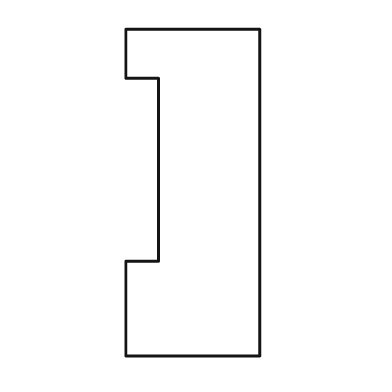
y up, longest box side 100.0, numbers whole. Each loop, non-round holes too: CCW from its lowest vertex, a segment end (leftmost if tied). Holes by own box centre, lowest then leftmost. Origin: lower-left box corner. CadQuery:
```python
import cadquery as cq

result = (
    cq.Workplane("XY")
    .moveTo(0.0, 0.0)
    .lineTo(41.0, 0.0)
    .lineTo(41.0, 100.0)
    .lineTo(0.0, 100.0)
    .lineTo(0.0, 85.0)
    .lineTo(10.0, 85.0)
    .lineTo(10.0, 29.0)
    .lineTo(0.0, 29.0)
    .close()
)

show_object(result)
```